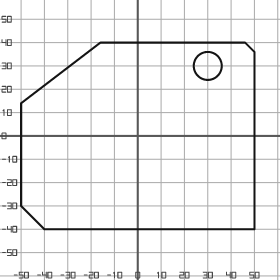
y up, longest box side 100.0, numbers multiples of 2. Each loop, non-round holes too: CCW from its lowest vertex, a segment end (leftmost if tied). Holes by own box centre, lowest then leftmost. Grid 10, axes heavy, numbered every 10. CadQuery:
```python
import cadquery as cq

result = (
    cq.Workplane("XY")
    .moveTo(-40.0, -40.0)
    .lineTo(50.0, -40.0)
    .lineTo(50.0, 36.0)
    .lineTo(46.0, 40.0)
    .lineTo(-16.0, 40.0)
    .lineTo(-50.0, 14.0)
    .lineTo(-50.0, -30.0)
    .close()
    .moveTo(30.0, 30.0)
    .circle(6.0)
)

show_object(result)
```